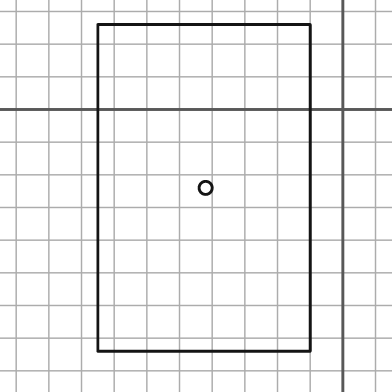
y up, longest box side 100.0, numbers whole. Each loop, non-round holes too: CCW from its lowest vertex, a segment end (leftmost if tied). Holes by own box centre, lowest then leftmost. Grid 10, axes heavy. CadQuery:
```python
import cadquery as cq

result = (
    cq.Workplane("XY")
    .moveTo(-75.0, -74.0)
    .lineTo(-10.0, -74.0)
    .lineTo(-10.0, 26.0)
    .lineTo(-75.0, 26.0)
    .close()
    .moveTo(-42.0, -24.0)
    .circle(2.0)
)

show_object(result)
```